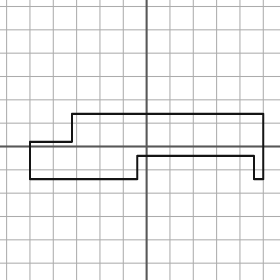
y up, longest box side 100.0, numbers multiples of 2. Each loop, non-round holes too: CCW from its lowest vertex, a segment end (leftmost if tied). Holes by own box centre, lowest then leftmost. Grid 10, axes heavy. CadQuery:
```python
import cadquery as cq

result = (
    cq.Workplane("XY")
    .moveTo(-50.0, -14.0)
    .lineTo(-4.0, -14.0)
    .lineTo(-4.0, -4.0)
    .lineTo(46.0, -4.0)
    .lineTo(46.0, -14.0)
    .lineTo(50.0, -14.0)
    .lineTo(50.0, 14.0)
    .lineTo(-32.0, 14.0)
    .lineTo(-32.0, 2.0)
    .lineTo(-50.0, 2.0)
    .close()
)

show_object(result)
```